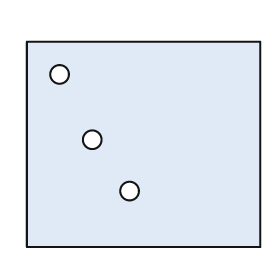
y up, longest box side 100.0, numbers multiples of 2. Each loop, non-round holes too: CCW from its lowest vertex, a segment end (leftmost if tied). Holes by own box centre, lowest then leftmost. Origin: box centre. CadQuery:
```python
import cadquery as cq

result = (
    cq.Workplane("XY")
    .moveTo(-50.0, -44.0)
    .lineTo(50.0, -44.0)
    .lineTo(50.0, 44.0)
    .lineTo(-50.0, 44.0)
    .close()
    .moveTo(-6.0, -20.0)
    .circle(4.0)
    .moveTo(-22.0, 2.0)
    .circle(4.0)
    .moveTo(-36.0, 30.0)
    .circle(4.0)
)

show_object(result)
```